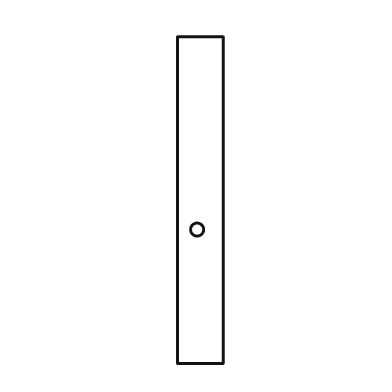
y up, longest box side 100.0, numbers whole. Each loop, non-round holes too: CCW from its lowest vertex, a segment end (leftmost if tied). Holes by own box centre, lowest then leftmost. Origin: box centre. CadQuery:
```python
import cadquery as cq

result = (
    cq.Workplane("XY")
    .moveTo(-7.0, -50.0)
    .lineTo(7.0, -50.0)
    .lineTo(7.0, 50.0)
    .lineTo(-7.0, 50.0)
    .close()
    .moveTo(-1.0, -9.0)
    .circle(2.0)
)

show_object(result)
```